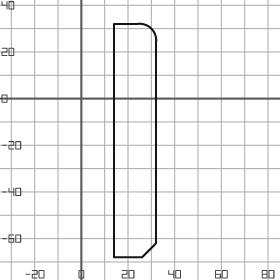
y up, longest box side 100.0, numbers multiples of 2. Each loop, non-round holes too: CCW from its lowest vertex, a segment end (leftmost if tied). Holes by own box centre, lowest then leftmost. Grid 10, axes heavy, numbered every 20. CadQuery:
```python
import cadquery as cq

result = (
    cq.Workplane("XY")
    .moveTo(14.0, -68.0)
    .lineTo(26.0, -68.0)
    .lineTo(32.0, -62.0)
    .lineTo(32.0, 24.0)
    .threePointArc((30.0, 30.0), (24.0, 32.0))
    .lineTo(14.0, 32.0)
    .close()
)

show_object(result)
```